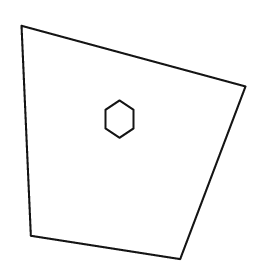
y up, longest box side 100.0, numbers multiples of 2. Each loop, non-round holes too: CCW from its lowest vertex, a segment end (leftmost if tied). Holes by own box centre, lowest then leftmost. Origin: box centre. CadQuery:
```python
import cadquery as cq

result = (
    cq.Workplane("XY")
    .moveTo(20.0, -50.0)
    .lineTo(48.0, 24.0)
    .lineTo(-48.0, 50.0)
    .lineTo(-44.0, -40.0)
    .close()
    .moveTo(-6.0, 2.0)
    .lineTo(0.0, 6.0)
    .lineTo(0.0, 14.0)
    .lineTo(-6.0, 18.0)
    .lineTo(-12.0, 14.0)
    .lineTo(-12.0, 6.0)
    .close()
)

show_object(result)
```